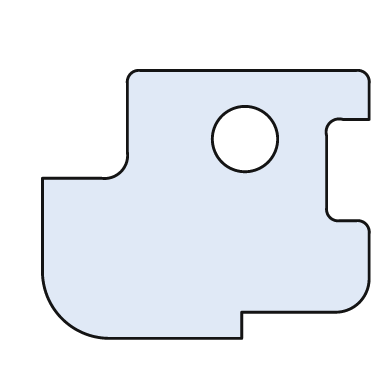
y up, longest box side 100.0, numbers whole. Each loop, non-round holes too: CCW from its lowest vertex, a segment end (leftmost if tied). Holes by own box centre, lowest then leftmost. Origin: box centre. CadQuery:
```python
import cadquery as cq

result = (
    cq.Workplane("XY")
    .moveTo(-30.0, -41.0)
    .lineTo(11.0, -41.0)
    .lineTo(11.0, -33.0)
    .lineTo(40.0, -33.0)
    .threePointArc((47.0, -30.0), (50.0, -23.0))
    .lineTo(50.0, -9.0)
    .threePointArc((49.0, -6.0), (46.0, -5.0))
    .lineTo(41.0, -5.0)
    .threePointArc((38.0, -4.0), (37.0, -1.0))
    .lineTo(37.0, 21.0)
    .threePointArc((38.0, 25.0), (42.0, 26.0))
    .lineTo(50.0, 26.0)
    .lineTo(50.0, 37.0)
    .threePointArc((49.0, 40.0), (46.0, 41.0))
    .lineTo(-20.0, 41.0)
    .threePointArc((-23.0, 40.0), (-24.0, 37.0))
    .lineTo(-24.0, 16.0)
    .threePointArc((-26.0, 10.0), (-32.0, 8.0))
    .lineTo(-50.0, 8.0)
    .lineTo(-50.0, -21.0)
    .threePointArc((-44.0, -35.0), (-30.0, -41.0))
    .close()
    .moveTo(12.0, 20.0)
    .circle(10.0)
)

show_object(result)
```